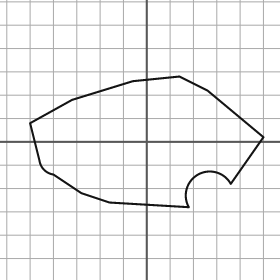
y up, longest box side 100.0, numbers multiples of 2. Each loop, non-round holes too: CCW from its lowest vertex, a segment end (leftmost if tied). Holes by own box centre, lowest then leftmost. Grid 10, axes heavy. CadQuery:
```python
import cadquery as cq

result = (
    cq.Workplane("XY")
    .moveTo(18.0, -28.0)
    .threePointArc((22.0, -14.0), (36.0, -18.0))
    .lineTo(50.0, 2.0)
    .lineTo(26.0, 22.0)
    .lineTo(14.0, 28.0)
    .lineTo(-6.0, 26.0)
    .lineTo(-32.0, 18.0)
    .lineTo(-50.0, 8.0)
    .lineTo(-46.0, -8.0)
    .threePointArc((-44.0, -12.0), (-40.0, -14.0))
    .lineTo(-28.0, -22.0)
    .lineTo(-16.0, -26.0)
    .close()
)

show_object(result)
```